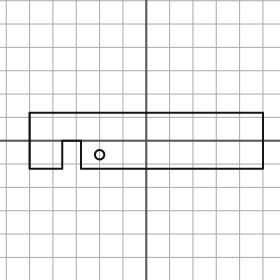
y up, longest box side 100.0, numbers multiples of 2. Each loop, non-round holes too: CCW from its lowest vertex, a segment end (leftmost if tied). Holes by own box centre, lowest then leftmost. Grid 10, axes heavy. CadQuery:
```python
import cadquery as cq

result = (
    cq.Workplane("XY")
    .moveTo(-50.0, -12.0)
    .lineTo(-36.0, -12.0)
    .lineTo(-36.0, 0.0)
    .lineTo(-28.0, 0.0)
    .lineTo(-28.0, -12.0)
    .lineTo(50.0, -12.0)
    .lineTo(50.0, 12.0)
    .lineTo(-50.0, 12.0)
    .close()
    .moveTo(-20.0, -6.0)
    .circle(2.0)
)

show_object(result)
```